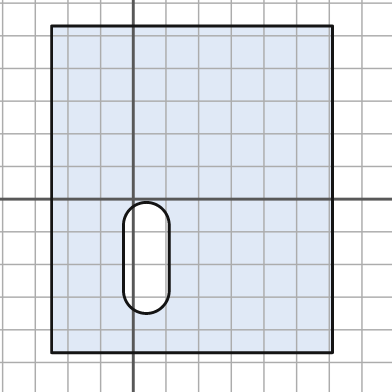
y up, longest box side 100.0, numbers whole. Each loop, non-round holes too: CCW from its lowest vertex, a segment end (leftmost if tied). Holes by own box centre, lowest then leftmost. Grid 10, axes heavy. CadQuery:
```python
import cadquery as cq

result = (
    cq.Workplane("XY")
    .moveTo(-25.0, -47.0)
    .lineTo(61.0, -47.0)
    .lineTo(61.0, 53.0)
    .lineTo(-25.0, 53.0)
    .close()
    .moveTo(-3.0, -28.0)
    .threePointArc((4.0, -35.0), (11.0, -28.0))
    .lineTo(11.0, -8.0)
    .threePointArc((4.0, -1.0), (-3.0, -8.0))
    .close()
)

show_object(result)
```